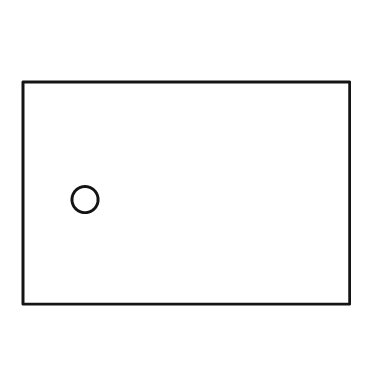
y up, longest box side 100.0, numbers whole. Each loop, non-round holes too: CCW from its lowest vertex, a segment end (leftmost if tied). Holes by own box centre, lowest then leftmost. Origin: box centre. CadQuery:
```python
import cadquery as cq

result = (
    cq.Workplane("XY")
    .moveTo(-50.0, -34.0)
    .lineTo(50.0, -34.0)
    .lineTo(50.0, 34.0)
    .lineTo(-50.0, 34.0)
    .close()
    .moveTo(-31.0, -2.0)
    .circle(4.0)
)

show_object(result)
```